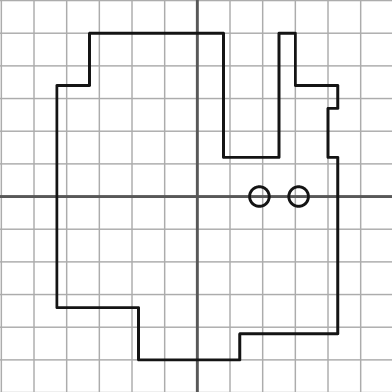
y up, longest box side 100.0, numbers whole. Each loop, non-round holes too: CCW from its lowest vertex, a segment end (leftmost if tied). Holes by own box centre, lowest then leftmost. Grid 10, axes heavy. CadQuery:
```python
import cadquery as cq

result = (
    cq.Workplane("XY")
    .moveTo(-18.0, -50.0)
    .lineTo(13.0, -50.0)
    .lineTo(13.0, -42.0)
    .lineTo(43.0, -42.0)
    .lineTo(43.0, 12.0)
    .lineTo(40.0, 12.0)
    .lineTo(40.0, 27.0)
    .lineTo(43.0, 27.0)
    .lineTo(43.0, 34.0)
    .lineTo(30.0, 34.0)
    .lineTo(30.0, 50.0)
    .lineTo(25.0, 50.0)
    .lineTo(25.0, 12.0)
    .lineTo(8.0, 12.0)
    .lineTo(8.0, 50.0)
    .lineTo(-33.0, 50.0)
    .lineTo(-33.0, 34.0)
    .lineTo(-43.0, 34.0)
    .lineTo(-43.0, -34.0)
    .lineTo(-18.0, -34.0)
    .close()
    .moveTo(19.0, 0.0)
    .circle(3.0)
    .moveTo(31.0, 0.0)
    .circle(3.0)
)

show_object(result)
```